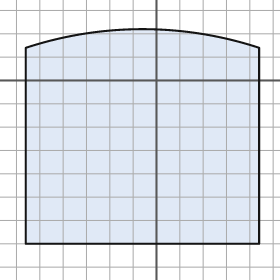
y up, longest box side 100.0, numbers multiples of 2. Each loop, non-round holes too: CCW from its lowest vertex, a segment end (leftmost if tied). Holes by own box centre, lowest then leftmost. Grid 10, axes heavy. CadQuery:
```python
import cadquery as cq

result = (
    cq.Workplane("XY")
    .moveTo(-56.0, -70.0)
    .lineTo(44.0, -70.0)
    .lineTo(44.0, 14.0)
    .threePointArc((-6.0, 22.0), (-56.0, 14.0))
    .close()
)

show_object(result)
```